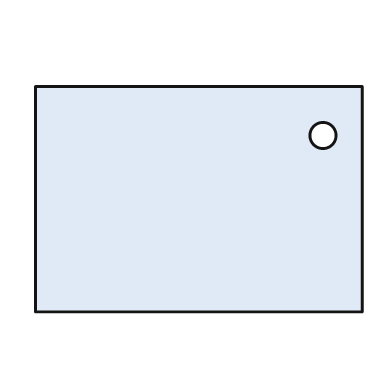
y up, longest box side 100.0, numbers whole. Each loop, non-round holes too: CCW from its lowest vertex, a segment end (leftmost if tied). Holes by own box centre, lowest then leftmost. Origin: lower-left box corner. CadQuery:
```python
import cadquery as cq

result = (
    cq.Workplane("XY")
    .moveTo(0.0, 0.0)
    .lineTo(100.0, 0.0)
    .lineTo(100.0, 69.0)
    .lineTo(0.0, 69.0)
    .close()
    .moveTo(88.0, 54.0)
    .circle(4.0)
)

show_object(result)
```